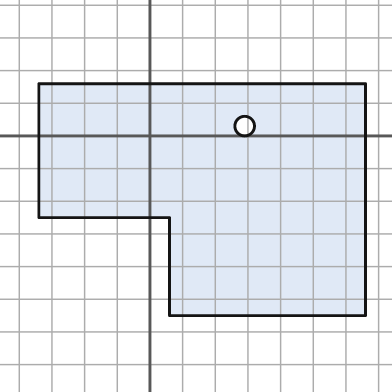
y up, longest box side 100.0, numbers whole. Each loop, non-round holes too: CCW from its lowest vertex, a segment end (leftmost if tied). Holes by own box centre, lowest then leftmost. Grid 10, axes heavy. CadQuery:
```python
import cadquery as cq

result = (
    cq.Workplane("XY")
    .moveTo(6.0, -55.0)
    .lineTo(66.0, -55.0)
    .lineTo(66.0, 16.0)
    .lineTo(-34.0, 16.0)
    .lineTo(-34.0, -25.0)
    .lineTo(6.0, -25.0)
    .close()
    .moveTo(29.0, 3.0)
    .circle(3.0)
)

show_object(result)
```